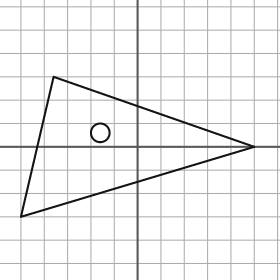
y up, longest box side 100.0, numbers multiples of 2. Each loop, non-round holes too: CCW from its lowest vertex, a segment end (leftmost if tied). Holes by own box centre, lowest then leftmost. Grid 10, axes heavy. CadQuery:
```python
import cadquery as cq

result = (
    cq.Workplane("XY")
    .moveTo(-50.0, -30.0)
    .lineTo(50.0, 0.0)
    .lineTo(-36.0, 30.0)
    .close()
    .moveTo(-16.0, 6.0)
    .circle(4.0)
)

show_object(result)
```